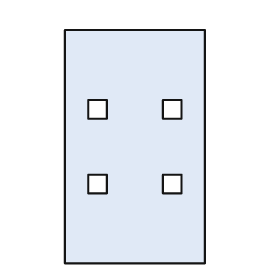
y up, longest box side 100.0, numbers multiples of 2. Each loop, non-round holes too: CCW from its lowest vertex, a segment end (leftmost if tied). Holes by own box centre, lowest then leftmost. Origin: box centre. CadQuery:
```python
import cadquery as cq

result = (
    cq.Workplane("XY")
    .moveTo(-30.0, -50.0)
    .lineTo(30.0, -50.0)
    .lineTo(30.0, 50.0)
    .lineTo(-30.0, 50.0)
    .close()
    .moveTo(-20.0, -20.0)
    .lineTo(-12.0, -20.0)
    .lineTo(-12.0, -12.0)
    .lineTo(-20.0, -12.0)
    .close()
    .moveTo(12.0, -20.0)
    .lineTo(20.0, -20.0)
    .lineTo(20.0, -12.0)
    .lineTo(12.0, -12.0)
    .close()
    .moveTo(-20.0, 12.0)
    .lineTo(-12.0, 12.0)
    .lineTo(-12.0, 20.0)
    .lineTo(-20.0, 20.0)
    .close()
    .moveTo(12.0, 12.0)
    .lineTo(20.0, 12.0)
    .lineTo(20.0, 20.0)
    .lineTo(12.0, 20.0)
    .close()
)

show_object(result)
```